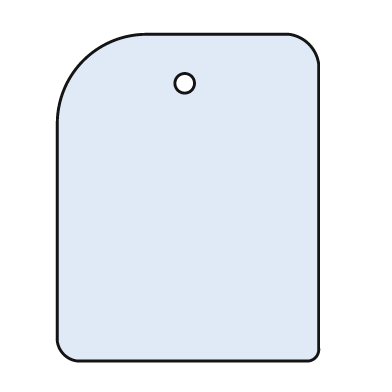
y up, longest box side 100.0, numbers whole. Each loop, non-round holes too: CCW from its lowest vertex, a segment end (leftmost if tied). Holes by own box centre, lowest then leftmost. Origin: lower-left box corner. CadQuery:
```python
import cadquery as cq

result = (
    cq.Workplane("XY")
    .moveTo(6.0, 0.0)
    .lineTo(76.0, 0.0)
    .threePointArc((79.0, 1.0), (80.0, 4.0))
    .lineTo(80.0, 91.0)
    .threePointArc((77.0, 97.0), (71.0, 100.0))
    .lineTo(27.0, 100.0)
    .threePointArc((8.0, 92.0), (0.0, 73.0))
    .lineTo(0.0, 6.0)
    .threePointArc((2.0, 2.0), (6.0, 0.0))
    .close()
    .moveTo(39.0, 85.0)
    .circle(3.0)
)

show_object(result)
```